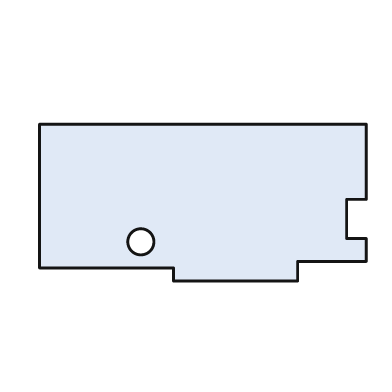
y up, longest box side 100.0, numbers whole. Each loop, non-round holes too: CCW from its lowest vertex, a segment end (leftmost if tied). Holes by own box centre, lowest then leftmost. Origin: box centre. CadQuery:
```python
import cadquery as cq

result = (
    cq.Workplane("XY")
    .moveTo(-9.0, -24.0)
    .lineTo(29.0, -24.0)
    .lineTo(29.0, -18.0)
    .lineTo(50.0, -18.0)
    .lineTo(50.0, -11.0)
    .lineTo(44.0, -11.0)
    .lineTo(44.0, 1.0)
    .lineTo(50.0, 1.0)
    .lineTo(50.0, 24.0)
    .lineTo(-50.0, 24.0)
    .lineTo(-50.0, -20.0)
    .lineTo(-9.0, -20.0)
    .close()
    .moveTo(-19.0, -12.0)
    .circle(4.0)
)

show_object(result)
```